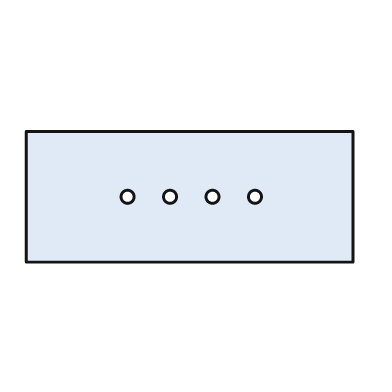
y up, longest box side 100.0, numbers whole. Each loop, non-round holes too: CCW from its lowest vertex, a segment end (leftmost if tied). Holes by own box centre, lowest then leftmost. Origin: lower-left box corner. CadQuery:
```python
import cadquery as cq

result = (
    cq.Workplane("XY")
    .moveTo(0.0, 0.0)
    .lineTo(100.0, 0.0)
    .lineTo(100.0, 40.0)
    .lineTo(0.0, 40.0)
    .close()
    .moveTo(31.0, 20.0)
    .circle(2.0)
    .moveTo(44.0, 20.0)
    .circle(2.0)
    .moveTo(57.0, 20.0)
    .circle(2.0)
    .moveTo(70.0, 20.0)
    .circle(2.0)
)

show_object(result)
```